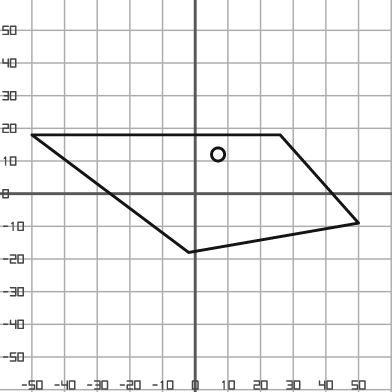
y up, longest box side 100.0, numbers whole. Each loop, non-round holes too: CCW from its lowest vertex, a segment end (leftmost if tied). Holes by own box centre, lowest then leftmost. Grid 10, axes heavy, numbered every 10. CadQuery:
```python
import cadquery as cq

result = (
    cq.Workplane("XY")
    .moveTo(-2.0, -18.0)
    .lineTo(50.0, -9.0)
    .lineTo(26.0, 18.0)
    .lineTo(-50.0, 18.0)
    .close()
    .moveTo(7.0, 12.0)
    .circle(2.0)
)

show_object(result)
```